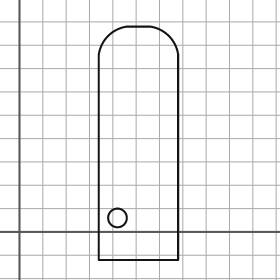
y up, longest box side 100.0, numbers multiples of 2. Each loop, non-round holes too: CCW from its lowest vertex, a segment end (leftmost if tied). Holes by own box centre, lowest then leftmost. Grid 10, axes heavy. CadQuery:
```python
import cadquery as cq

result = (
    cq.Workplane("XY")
    .moveTo(34.0, -12.0)
    .lineTo(68.0, -12.0)
    .lineTo(68.0, 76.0)
    .threePointArc((64.0, 84.0), (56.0, 88.0))
    .lineTo(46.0, 88.0)
    .threePointArc((38.0, 84.0), (34.0, 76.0))
    .close()
    .moveTo(42.0, 6.0)
    .circle(4.0)
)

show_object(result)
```